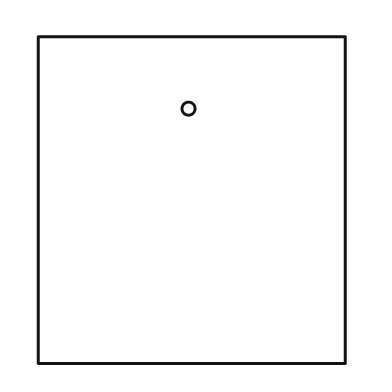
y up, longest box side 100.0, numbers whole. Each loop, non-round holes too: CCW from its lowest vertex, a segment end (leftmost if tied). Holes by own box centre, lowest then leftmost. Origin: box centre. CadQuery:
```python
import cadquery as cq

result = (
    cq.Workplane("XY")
    .moveTo(-47.0, -50.0)
    .lineTo(47.0, -50.0)
    .lineTo(47.0, 50.0)
    .lineTo(-47.0, 50.0)
    .close()
    .moveTo(-1.0, 28.0)
    .circle(2.0)
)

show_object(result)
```